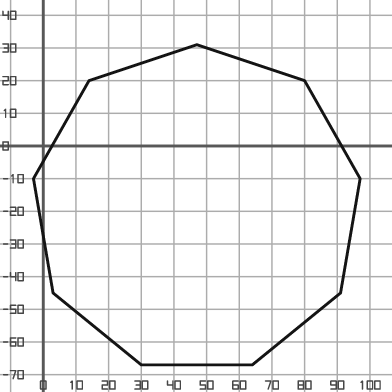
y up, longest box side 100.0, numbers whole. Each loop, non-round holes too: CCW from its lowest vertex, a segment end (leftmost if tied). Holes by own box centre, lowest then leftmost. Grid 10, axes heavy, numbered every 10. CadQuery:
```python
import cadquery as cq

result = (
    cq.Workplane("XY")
    .moveTo(30.0, -67.0)
    .lineTo(64.0, -67.0)
    .lineTo(91.0, -45.0)
    .lineTo(97.0, -10.0)
    .lineTo(80.0, 20.0)
    .lineTo(47.0, 31.0)
    .lineTo(14.0, 20.0)
    .lineTo(-3.0, -10.0)
    .lineTo(3.0, -45.0)
    .close()
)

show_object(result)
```